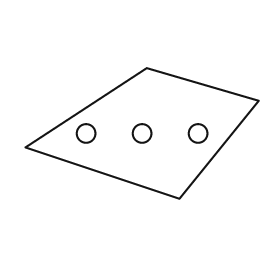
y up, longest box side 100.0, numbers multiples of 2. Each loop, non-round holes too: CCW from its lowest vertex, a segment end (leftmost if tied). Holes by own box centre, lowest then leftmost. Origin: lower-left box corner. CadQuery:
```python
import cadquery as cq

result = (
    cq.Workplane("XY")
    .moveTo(66.0, 0.0)
    .lineTo(100.0, 42.0)
    .lineTo(52.0, 56.0)
    .lineTo(0.0, 22.0)
    .close()
    .moveTo(26.0, 28.0)
    .circle(4.0)
    .moveTo(50.0, 28.0)
    .circle(4.0)
    .moveTo(74.0, 28.0)
    .circle(4.0)
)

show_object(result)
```